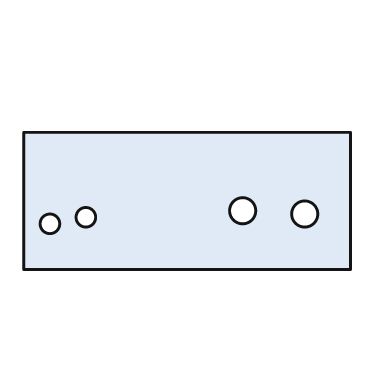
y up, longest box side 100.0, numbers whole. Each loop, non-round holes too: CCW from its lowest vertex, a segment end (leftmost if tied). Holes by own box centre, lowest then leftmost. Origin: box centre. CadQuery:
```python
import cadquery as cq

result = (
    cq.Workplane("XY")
    .moveTo(-50.0, -21.0)
    .lineTo(50.0, -21.0)
    .lineTo(50.0, 21.0)
    .lineTo(-50.0, 21.0)
    .close()
    .moveTo(-42.0, -7.0)
    .circle(3.0)
    .moveTo(-31.0, -5.0)
    .circle(3.0)
    .moveTo(36.0, -4.0)
    .circle(4.0)
    .moveTo(17.0, -3.0)
    .circle(4.0)
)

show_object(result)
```